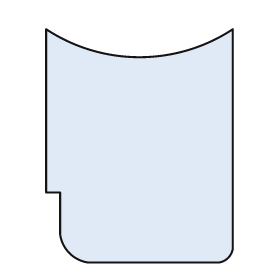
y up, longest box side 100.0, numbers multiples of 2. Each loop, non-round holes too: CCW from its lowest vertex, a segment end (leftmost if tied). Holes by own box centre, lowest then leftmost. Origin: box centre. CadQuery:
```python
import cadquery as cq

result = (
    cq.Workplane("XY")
    .moveTo(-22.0, -50.0)
    .lineTo(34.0, -50.0)
    .threePointArc((38.0, -48.0), (40.0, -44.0))
    .lineTo(40.0, 50.0)
    .threePointArc((0.0, 38.0), (-40.0, 50.0))
    .lineTo(-40.0, -20.0)
    .lineTo(-34.0, -20.0)
    .lineTo(-34.0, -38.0)
    .threePointArc((-30.0, -46.0), (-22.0, -50.0))
    .close()
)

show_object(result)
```